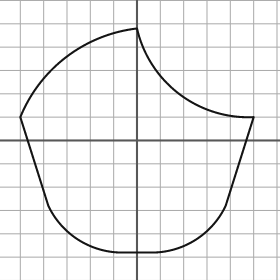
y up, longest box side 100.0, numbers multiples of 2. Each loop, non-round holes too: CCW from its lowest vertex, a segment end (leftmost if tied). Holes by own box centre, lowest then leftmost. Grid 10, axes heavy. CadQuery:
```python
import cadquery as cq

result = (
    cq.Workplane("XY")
    .moveTo(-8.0, -48.0)
    .lineTo(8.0, -48.0)
    .threePointArc((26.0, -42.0), (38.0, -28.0))
    .lineTo(50.0, 10.0)
    .threePointArc((18.0, 20.0), (0.0, 48.0))
    .threePointArc((-30.0, 36.0), (-50.0, 10.0))
    .lineTo(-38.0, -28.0)
    .threePointArc((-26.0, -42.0), (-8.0, -48.0))
    .close()
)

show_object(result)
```